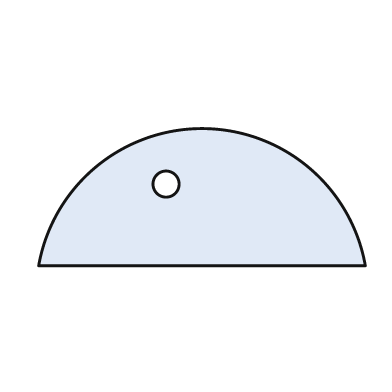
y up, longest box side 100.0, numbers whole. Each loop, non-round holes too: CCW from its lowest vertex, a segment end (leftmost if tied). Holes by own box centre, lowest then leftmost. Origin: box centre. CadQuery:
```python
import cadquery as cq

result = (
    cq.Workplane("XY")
    .moveTo(-50.0, -21.0)
    .lineTo(50.0, -21.0)
    .threePointArc((0.0, 21.0), (-50.0, -21.0))
    .close()
    .moveTo(-11.0, 4.0)
    .circle(4.0)
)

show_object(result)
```